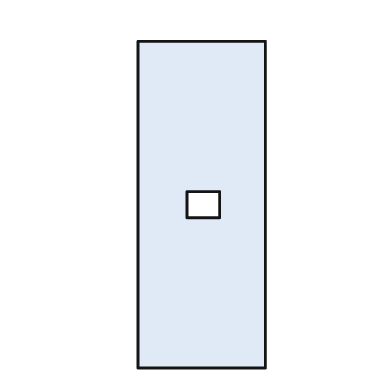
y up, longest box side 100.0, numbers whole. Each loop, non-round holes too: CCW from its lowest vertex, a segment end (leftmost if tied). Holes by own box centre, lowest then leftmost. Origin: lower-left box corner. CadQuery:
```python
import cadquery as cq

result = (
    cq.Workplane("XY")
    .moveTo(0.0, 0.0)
    .lineTo(39.0, 0.0)
    .lineTo(39.0, 100.0)
    .lineTo(0.0, 100.0)
    .close()
    .moveTo(15.0, 46.0)
    .lineTo(25.0, 46.0)
    .lineTo(25.0, 54.0)
    .lineTo(15.0, 54.0)
    .close()
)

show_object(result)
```